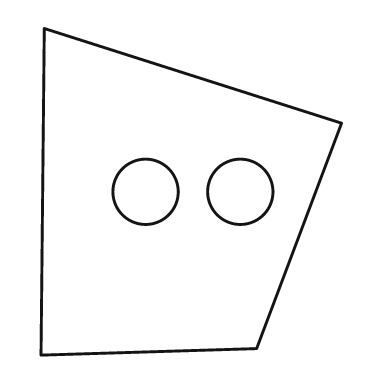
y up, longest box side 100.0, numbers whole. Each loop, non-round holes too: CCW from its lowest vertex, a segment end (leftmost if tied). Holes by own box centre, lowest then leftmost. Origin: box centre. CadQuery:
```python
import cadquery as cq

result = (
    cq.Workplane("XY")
    .moveTo(-46.0, -50.0)
    .lineTo(20.0, -48.0)
    .lineTo(46.0, 21.0)
    .lineTo(-45.0, 50.0)
    .close()
    .moveTo(-14.0, 0.0)
    .circle(10.0)
    .moveTo(15.0, 0.0)
    .circle(10.0)
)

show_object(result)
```